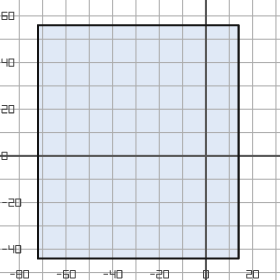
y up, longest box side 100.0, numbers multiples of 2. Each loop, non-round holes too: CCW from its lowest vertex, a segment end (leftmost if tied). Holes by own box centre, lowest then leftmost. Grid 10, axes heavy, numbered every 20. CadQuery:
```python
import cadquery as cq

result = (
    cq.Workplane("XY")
    .moveTo(-72.0, -44.0)
    .lineTo(14.0, -44.0)
    .lineTo(14.0, 56.0)
    .lineTo(-72.0, 56.0)
    .close()
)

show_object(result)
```